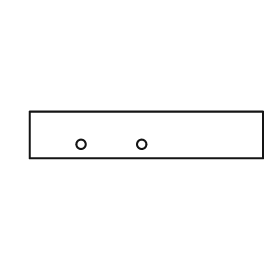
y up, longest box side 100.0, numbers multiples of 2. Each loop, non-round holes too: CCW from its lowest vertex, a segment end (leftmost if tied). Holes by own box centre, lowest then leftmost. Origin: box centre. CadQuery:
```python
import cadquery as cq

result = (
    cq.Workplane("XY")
    .moveTo(-50.0, -10.0)
    .lineTo(50.0, -10.0)
    .lineTo(50.0, 10.0)
    .lineTo(-50.0, 10.0)
    .close()
    .moveTo(-28.0, -4.0)
    .circle(2.0)
    .moveTo(-2.0, -4.0)
    .circle(2.0)
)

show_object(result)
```